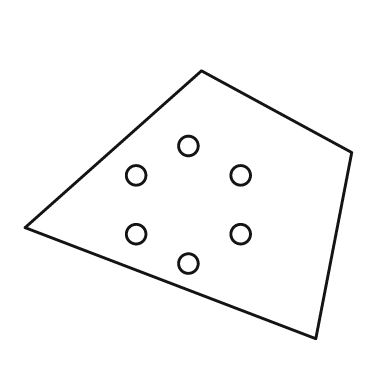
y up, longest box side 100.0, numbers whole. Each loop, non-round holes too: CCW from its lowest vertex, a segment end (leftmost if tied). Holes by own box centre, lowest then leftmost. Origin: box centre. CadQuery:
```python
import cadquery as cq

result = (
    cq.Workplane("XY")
    .moveTo(39.0, -41.0)
    .lineTo(50.0, 16.0)
    .lineTo(4.0, 41.0)
    .lineTo(-50.0, -7.0)
    .close()
    .moveTo(0.0, -18.0)
    .circle(3.0)
    .moveTo(-16.0, -9.0)
    .circle(3.0)
    .moveTo(16.0, -9.0)
    .circle(3.0)
    .moveTo(-16.0, 9.0)
    .circle(3.0)
    .moveTo(16.0, 9.0)
    .circle(3.0)
    .moveTo(0.0, 18.0)
    .circle(3.0)
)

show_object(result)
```